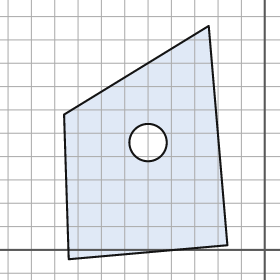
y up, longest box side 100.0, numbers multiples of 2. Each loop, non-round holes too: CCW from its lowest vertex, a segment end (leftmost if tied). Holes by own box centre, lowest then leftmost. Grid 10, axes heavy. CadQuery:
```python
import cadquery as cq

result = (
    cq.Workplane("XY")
    .moveTo(-84.0, -4.0)
    .lineTo(-16.0, 2.0)
    .lineTo(-24.0, 96.0)
    .lineTo(-86.0, 58.0)
    .close()
    .moveTo(-50.0, 46.0)
    .circle(8.0)
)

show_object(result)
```